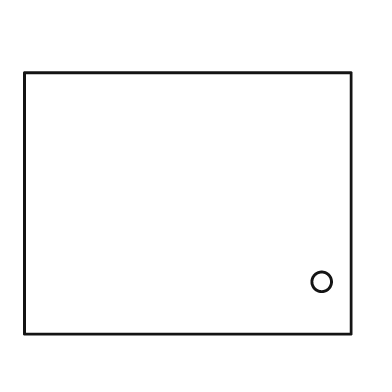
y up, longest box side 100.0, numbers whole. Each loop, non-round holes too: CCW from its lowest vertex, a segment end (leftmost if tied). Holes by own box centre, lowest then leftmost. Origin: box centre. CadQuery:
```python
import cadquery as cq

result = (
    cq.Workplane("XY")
    .moveTo(-50.0, -40.0)
    .lineTo(50.0, -40.0)
    .lineTo(50.0, 40.0)
    .lineTo(-50.0, 40.0)
    .close()
    .moveTo(41.0, -24.0)
    .circle(3.0)
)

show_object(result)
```